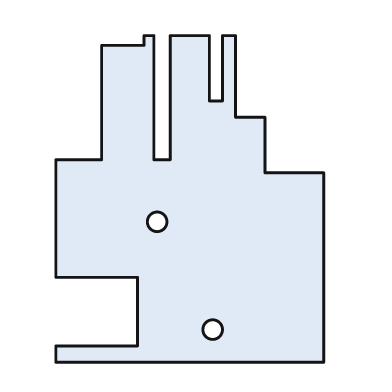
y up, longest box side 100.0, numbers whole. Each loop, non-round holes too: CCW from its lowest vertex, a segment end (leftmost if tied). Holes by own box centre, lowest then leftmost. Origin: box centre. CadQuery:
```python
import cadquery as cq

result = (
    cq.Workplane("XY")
    .moveTo(-41.0, -50.0)
    .lineTo(41.0, -50.0)
    .lineTo(41.0, 8.0)
    .lineTo(23.0, 8.0)
    .lineTo(23.0, 25.0)
    .lineTo(14.0, 25.0)
    .lineTo(14.0, 50.0)
    .lineTo(10.0, 50.0)
    .lineTo(10.0, 30.0)
    .lineTo(6.0, 30.0)
    .lineTo(6.0, 50.0)
    .lineTo(-6.0, 50.0)
    .lineTo(-6.0, 12.0)
    .lineTo(-11.0, 12.0)
    .lineTo(-11.0, 50.0)
    .lineTo(-14.0, 50.0)
    .lineTo(-14.0, 47.0)
    .lineTo(-27.0, 47.0)
    .lineTo(-27.0, 12.0)
    .lineTo(-41.0, 12.0)
    .lineTo(-41.0, -24.0)
    .lineTo(-16.0, -24.0)
    .lineTo(-16.0, -45.0)
    .lineTo(-41.0, -45.0)
    .close()
    .moveTo(7.0, -40.0)
    .circle(3.0)
    .moveTo(-10.0, -7.0)
    .circle(3.0)
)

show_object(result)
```